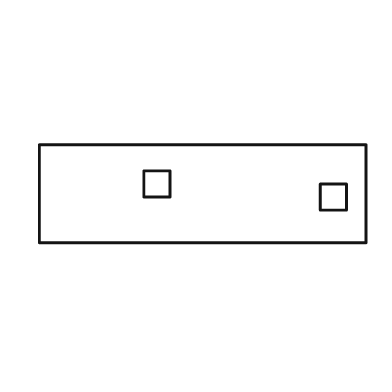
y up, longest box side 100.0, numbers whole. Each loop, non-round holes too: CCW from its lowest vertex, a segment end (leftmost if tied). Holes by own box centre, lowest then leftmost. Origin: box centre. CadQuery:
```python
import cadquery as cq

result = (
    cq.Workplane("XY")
    .moveTo(-50.0, -15.0)
    .lineTo(50.0, -15.0)
    .lineTo(50.0, 15.0)
    .lineTo(-50.0, 15.0)
    .close()
    .moveTo(36.0, -5.0)
    .lineTo(44.0, -5.0)
    .lineTo(44.0, 3.0)
    .lineTo(36.0, 3.0)
    .close()
    .moveTo(-18.0, -1.0)
    .lineTo(-10.0, -1.0)
    .lineTo(-10.0, 7.0)
    .lineTo(-18.0, 7.0)
    .close()
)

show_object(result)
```